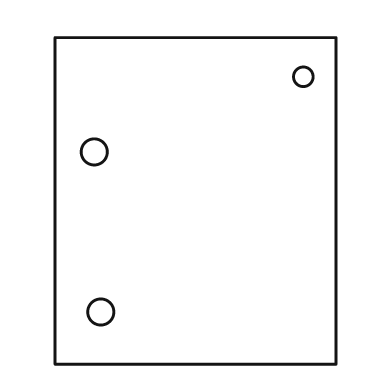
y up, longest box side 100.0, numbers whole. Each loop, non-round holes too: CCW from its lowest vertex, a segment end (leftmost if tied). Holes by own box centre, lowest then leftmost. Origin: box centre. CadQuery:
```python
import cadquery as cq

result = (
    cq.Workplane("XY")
    .moveTo(-43.0, -50.0)
    .lineTo(43.0, -50.0)
    .lineTo(43.0, 50.0)
    .lineTo(-43.0, 50.0)
    .close()
    .moveTo(-29.0, -34.0)
    .circle(4.0)
    .moveTo(-31.0, 15.0)
    .circle(4.0)
    .moveTo(33.0, 38.0)
    .circle(3.0)
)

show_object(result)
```